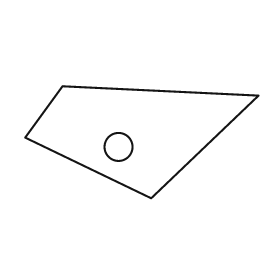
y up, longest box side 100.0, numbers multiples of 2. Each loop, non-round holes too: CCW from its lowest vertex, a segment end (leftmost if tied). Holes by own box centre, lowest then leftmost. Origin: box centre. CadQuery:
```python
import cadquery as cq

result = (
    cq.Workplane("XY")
    .moveTo(4.0, -24.0)
    .lineTo(50.0, 20.0)
    .lineTo(-34.0, 24.0)
    .lineTo(-50.0, 2.0)
    .close()
    .moveTo(-10.0, -2.0)
    .circle(6.0)
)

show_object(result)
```